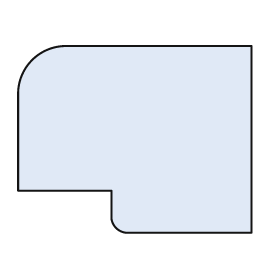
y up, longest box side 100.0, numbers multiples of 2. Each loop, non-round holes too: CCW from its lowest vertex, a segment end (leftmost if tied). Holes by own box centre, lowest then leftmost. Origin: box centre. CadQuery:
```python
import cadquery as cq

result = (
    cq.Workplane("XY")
    .moveTo(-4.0, -40.0)
    .lineTo(50.0, -40.0)
    .lineTo(50.0, 40.0)
    .lineTo(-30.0, 40.0)
    .threePointArc((-44.0, 34.0), (-50.0, 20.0))
    .lineTo(-50.0, -22.0)
    .lineTo(-10.0, -22.0)
    .lineTo(-10.0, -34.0)
    .threePointArc((-8.0, -38.0), (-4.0, -40.0))
    .close()
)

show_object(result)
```